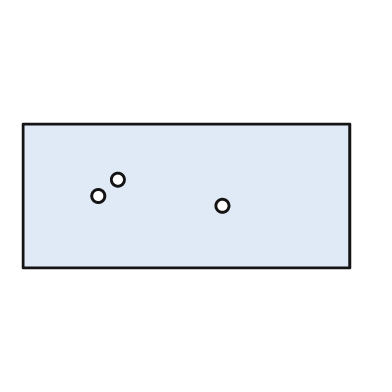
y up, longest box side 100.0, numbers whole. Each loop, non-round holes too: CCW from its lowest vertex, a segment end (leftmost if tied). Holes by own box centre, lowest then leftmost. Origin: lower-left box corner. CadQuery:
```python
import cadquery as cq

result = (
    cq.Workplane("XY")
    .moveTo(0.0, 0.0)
    .lineTo(100.0, 0.0)
    .lineTo(100.0, 44.0)
    .lineTo(0.0, 44.0)
    .close()
    .moveTo(61.0, 19.0)
    .circle(2.0)
    .moveTo(23.0, 22.0)
    .circle(2.0)
    .moveTo(29.0, 27.0)
    .circle(2.0)
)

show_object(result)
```